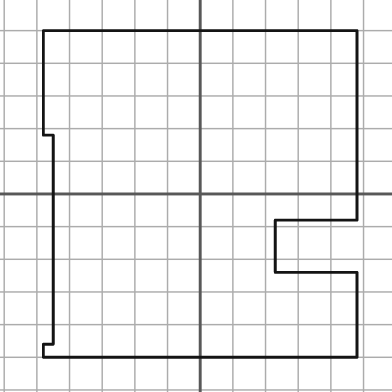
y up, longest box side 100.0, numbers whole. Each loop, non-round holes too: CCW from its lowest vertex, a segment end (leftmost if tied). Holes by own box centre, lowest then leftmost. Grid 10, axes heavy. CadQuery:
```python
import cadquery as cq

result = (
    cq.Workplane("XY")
    .moveTo(-48.0, -50.0)
    .lineTo(48.0, -50.0)
    .lineTo(48.0, -24.0)
    .lineTo(23.0, -24.0)
    .lineTo(23.0, -8.0)
    .lineTo(48.0, -8.0)
    .lineTo(48.0, 50.0)
    .lineTo(-48.0, 50.0)
    .lineTo(-48.0, 18.0)
    .lineTo(-45.0, 18.0)
    .lineTo(-45.0, -46.0)
    .lineTo(-48.0, -46.0)
    .close()
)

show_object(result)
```